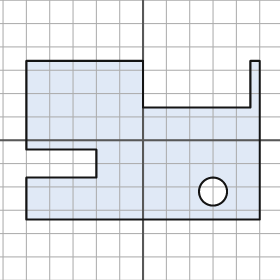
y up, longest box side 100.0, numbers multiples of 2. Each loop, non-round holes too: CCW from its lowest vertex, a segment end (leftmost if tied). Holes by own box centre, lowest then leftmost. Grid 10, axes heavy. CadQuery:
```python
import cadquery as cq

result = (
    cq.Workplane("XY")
    .moveTo(-50.0, -34.0)
    .lineTo(50.0, -34.0)
    .lineTo(50.0, 34.0)
    .lineTo(46.0, 34.0)
    .lineTo(46.0, 14.0)
    .lineTo(0.0, 14.0)
    .lineTo(0.0, 34.0)
    .lineTo(-50.0, 34.0)
    .lineTo(-50.0, -4.0)
    .lineTo(-20.0, -4.0)
    .lineTo(-20.0, -16.0)
    .lineTo(-50.0, -16.0)
    .close()
    .moveTo(30.0, -22.0)
    .circle(6.0)
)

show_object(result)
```